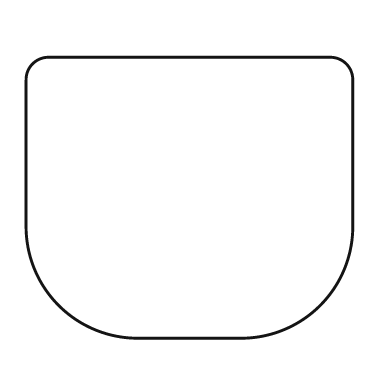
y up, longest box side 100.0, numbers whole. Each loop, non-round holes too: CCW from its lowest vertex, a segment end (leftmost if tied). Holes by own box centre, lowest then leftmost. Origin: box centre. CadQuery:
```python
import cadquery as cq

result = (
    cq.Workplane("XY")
    .moveTo(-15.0, -43.0)
    .lineTo(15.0, -43.0)
    .threePointArc((40.0, -33.0), (50.0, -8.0))
    .lineTo(50.0, 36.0)
    .threePointArc((48.0, 41.0), (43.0, 43.0))
    .lineTo(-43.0, 43.0)
    .threePointArc((-48.0, 41.0), (-50.0, 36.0))
    .lineTo(-50.0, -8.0)
    .threePointArc((-40.0, -33.0), (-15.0, -43.0))
    .close()
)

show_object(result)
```